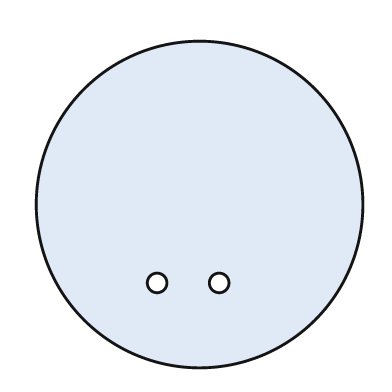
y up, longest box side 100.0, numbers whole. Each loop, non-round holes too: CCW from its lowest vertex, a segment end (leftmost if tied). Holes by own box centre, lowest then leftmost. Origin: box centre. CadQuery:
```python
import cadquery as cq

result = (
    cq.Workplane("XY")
    .moveTo(0.0, 0.0)
    .circle(50.0)
    .moveTo(-13.0, -24.0)
    .circle(3.0)
    .moveTo(6.0, -24.0)
    .circle(3.0)
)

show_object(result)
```